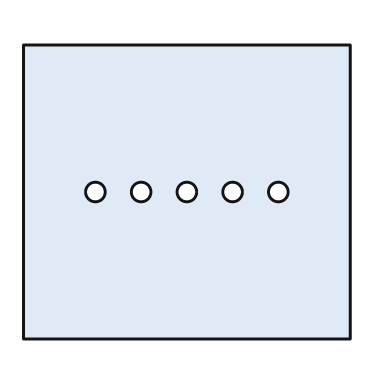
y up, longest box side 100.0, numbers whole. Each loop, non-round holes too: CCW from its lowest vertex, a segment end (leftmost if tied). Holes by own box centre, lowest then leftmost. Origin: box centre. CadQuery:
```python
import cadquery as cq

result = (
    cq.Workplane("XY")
    .moveTo(-50.0, -45.0)
    .lineTo(50.0, -45.0)
    .lineTo(50.0, 45.0)
    .lineTo(-50.0, 45.0)
    .close()
    .moveTo(-28.0, 0.0)
    .circle(3.0)
    .moveTo(-14.0, 0.0)
    .circle(3.0)
    .moveTo(0.0, 0.0)
    .circle(3.0)
    .moveTo(14.0, 0.0)
    .circle(3.0)
    .moveTo(28.0, 0.0)
    .circle(3.0)
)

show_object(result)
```